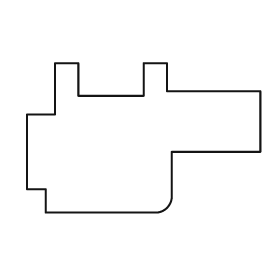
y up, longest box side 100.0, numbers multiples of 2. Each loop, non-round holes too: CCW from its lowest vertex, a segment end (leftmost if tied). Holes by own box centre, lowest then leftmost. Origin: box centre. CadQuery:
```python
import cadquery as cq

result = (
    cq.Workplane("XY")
    .moveTo(-42.0, -32.0)
    .lineTo(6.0, -32.0)
    .threePointArc((10.0, -30.0), (12.0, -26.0))
    .lineTo(12.0, -6.0)
    .lineTo(50.0, -6.0)
    .lineTo(50.0, 20.0)
    .lineTo(10.0, 20.0)
    .lineTo(10.0, 32.0)
    .lineTo(0.0, 32.0)
    .lineTo(0.0, 18.0)
    .lineTo(-28.0, 18.0)
    .lineTo(-28.0, 32.0)
    .lineTo(-38.0, 32.0)
    .lineTo(-38.0, 10.0)
    .lineTo(-50.0, 10.0)
    .lineTo(-50.0, -22.0)
    .lineTo(-42.0, -22.0)
    .close()
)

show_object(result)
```